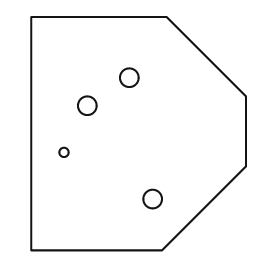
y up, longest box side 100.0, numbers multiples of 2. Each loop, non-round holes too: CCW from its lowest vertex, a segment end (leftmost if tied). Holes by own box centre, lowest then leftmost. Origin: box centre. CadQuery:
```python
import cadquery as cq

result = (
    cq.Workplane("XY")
    .moveTo(-46.0, -50.0)
    .lineTo(10.0, -50.0)
    .lineTo(46.0, -14.0)
    .lineTo(46.0, 16.0)
    .lineTo(12.0, 50.0)
    .lineTo(-46.0, 50.0)
    .close()
    .moveTo(6.0, -28.0)
    .circle(4.0)
    .moveTo(-32.0, -8.0)
    .circle(2.0)
    .moveTo(-22.0, 12.0)
    .circle(4.0)
    .moveTo(-4.0, 24.0)
    .circle(4.0)
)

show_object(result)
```